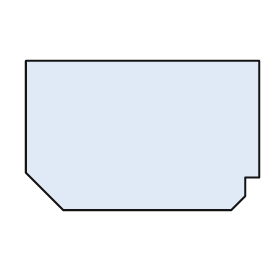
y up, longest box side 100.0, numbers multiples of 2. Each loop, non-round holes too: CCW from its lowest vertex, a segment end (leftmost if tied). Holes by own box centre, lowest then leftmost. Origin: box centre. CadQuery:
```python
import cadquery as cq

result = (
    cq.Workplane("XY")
    .moveTo(-34.0, -32.0)
    .lineTo(38.0, -32.0)
    .lineTo(44.0, -26.0)
    .lineTo(44.0, -18.0)
    .lineTo(50.0, -18.0)
    .lineTo(50.0, 32.0)
    .lineTo(-50.0, 32.0)
    .lineTo(-50.0, -16.0)
    .close()
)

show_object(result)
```